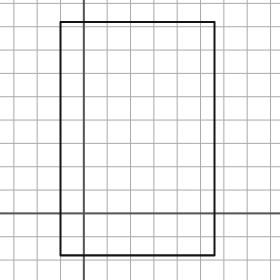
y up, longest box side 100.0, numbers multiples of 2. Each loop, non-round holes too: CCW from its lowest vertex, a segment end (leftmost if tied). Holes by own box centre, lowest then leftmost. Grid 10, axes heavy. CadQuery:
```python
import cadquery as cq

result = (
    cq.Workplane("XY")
    .moveTo(-10.0, -18.0)
    .lineTo(56.0, -18.0)
    .lineTo(56.0, 82.0)
    .lineTo(-10.0, 82.0)
    .close()
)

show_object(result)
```